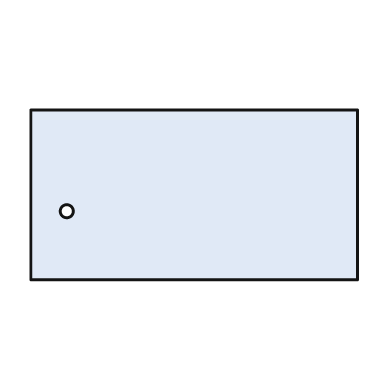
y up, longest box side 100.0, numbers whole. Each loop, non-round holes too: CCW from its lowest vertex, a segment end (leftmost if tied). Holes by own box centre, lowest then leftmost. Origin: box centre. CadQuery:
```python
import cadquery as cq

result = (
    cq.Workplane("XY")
    .moveTo(-50.0, -26.0)
    .lineTo(50.0, -26.0)
    .lineTo(50.0, 26.0)
    .lineTo(-50.0, 26.0)
    .close()
    .moveTo(-39.0, -5.0)
    .circle(2.0)
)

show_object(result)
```